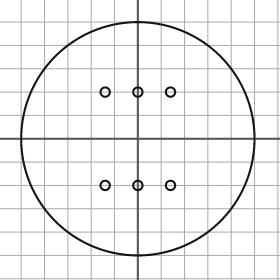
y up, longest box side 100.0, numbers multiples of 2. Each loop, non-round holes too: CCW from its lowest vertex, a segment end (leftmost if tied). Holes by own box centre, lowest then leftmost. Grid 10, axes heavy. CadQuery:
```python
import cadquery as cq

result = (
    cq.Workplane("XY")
    .moveTo(0.0, 0.0)
    .circle(50.0)
    .moveTo(-14.0, -20.0)
    .circle(2.0)
    .moveTo(0.0, -20.0)
    .circle(2.0)
    .moveTo(14.0, -20.0)
    .circle(2.0)
    .moveTo(-14.0, 20.0)
    .circle(2.0)
    .moveTo(0.0, 20.0)
    .circle(2.0)
    .moveTo(14.0, 20.0)
    .circle(2.0)
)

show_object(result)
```